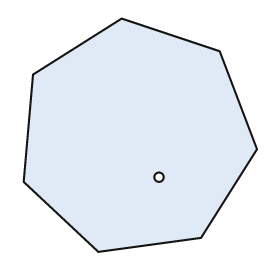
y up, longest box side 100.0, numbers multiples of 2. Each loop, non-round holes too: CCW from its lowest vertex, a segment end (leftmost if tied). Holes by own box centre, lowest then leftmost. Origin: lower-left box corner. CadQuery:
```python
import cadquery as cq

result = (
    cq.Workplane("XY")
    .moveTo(32.0, 0.0)
    .lineTo(76.0, 6.0)
    .lineTo(100.0, 44.0)
    .lineTo(84.0, 86.0)
    .lineTo(42.0, 100.0)
    .lineTo(4.0, 76.0)
    .lineTo(0.0, 30.0)
    .close()
    .moveTo(58.0, 32.0)
    .circle(2.0)
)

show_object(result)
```